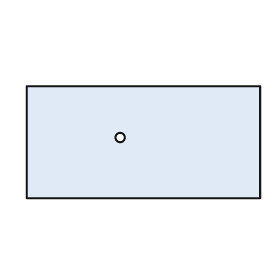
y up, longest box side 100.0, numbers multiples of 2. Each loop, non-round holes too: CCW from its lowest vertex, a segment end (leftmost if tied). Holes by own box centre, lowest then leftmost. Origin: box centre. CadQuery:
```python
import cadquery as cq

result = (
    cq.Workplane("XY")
    .moveTo(-50.0, -24.0)
    .lineTo(50.0, -24.0)
    .lineTo(50.0, 24.0)
    .lineTo(-50.0, 24.0)
    .close()
    .moveTo(-10.0, 2.0)
    .circle(2.0)
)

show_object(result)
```